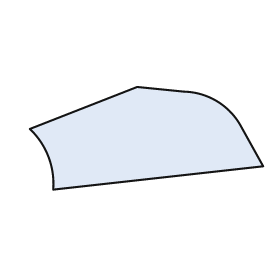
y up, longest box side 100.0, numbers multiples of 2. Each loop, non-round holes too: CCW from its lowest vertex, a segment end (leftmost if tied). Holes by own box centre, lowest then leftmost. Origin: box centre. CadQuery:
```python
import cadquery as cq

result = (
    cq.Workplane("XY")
    .moveTo(-40.0, -22.0)
    .lineTo(50.0, -12.0)
    .lineTo(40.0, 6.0)
    .threePointArc((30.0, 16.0), (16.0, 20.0))
    .lineTo(-4.0, 22.0)
    .lineTo(-50.0, 4.0)
    .threePointArc((-42.0, -8.0), (-40.0, -22.0))
    .close()
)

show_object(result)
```